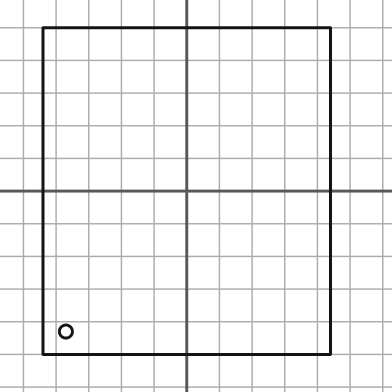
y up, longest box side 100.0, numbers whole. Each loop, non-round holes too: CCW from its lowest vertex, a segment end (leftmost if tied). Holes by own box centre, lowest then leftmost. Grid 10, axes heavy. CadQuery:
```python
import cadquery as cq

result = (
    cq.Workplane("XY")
    .moveTo(-44.0, -50.0)
    .lineTo(44.0, -50.0)
    .lineTo(44.0, 50.0)
    .lineTo(-44.0, 50.0)
    .close()
    .moveTo(-37.0, -43.0)
    .circle(2.0)
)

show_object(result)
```